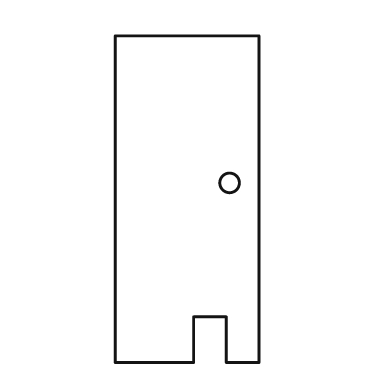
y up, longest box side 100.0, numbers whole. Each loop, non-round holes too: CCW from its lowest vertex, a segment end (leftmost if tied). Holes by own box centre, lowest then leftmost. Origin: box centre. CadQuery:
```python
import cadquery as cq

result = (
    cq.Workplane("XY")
    .moveTo(-22.0, -50.0)
    .lineTo(2.0, -50.0)
    .lineTo(2.0, -36.0)
    .lineTo(12.0, -36.0)
    .lineTo(12.0, -50.0)
    .lineTo(22.0, -50.0)
    .lineTo(22.0, 50.0)
    .lineTo(-22.0, 50.0)
    .close()
    .moveTo(13.0, 5.0)
    .circle(3.0)
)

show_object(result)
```